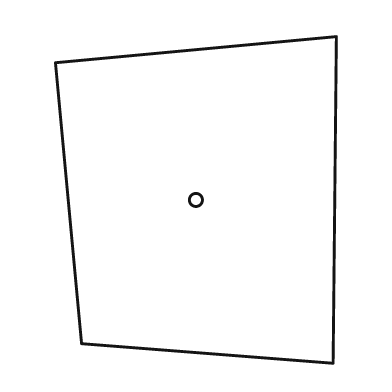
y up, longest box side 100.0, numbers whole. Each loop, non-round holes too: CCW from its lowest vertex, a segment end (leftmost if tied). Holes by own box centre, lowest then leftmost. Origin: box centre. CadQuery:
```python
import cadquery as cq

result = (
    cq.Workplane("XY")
    .moveTo(42.0, -50.0)
    .lineTo(43.0, 50.0)
    .lineTo(-43.0, 42.0)
    .lineTo(-35.0, -44.0)
    .close()
    .moveTo(0.0, 0.0)
    .circle(2.0)
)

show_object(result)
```